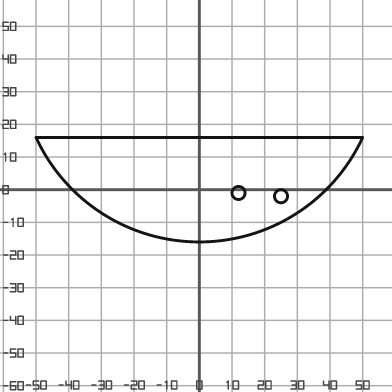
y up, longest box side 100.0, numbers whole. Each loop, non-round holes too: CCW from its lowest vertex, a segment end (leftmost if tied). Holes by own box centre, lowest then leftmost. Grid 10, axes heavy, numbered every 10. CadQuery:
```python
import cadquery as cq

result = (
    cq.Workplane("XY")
    .moveTo(-50.0, 16.0)
    .threePointArc((0.0, -16.0), (50.0, 16.0))
    .close()
    .moveTo(25.0, -2.0)
    .circle(2.0)
    .moveTo(12.0, -1.0)
    .circle(2.0)
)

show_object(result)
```